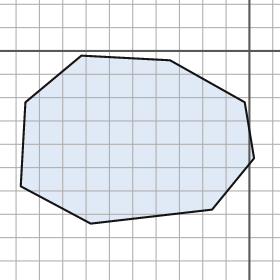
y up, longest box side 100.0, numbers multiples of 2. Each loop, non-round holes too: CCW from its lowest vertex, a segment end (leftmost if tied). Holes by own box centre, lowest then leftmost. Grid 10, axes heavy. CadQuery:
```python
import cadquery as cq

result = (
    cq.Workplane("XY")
    .moveTo(-68.0, -74.0)
    .lineTo(-16.0, -68.0)
    .lineTo(2.0, -46.0)
    .lineTo(-2.0, -22.0)
    .lineTo(-34.0, -4.0)
    .lineTo(-72.0, -2.0)
    .lineTo(-96.0, -22.0)
    .lineTo(-98.0, -58.0)
    .close()
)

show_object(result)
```